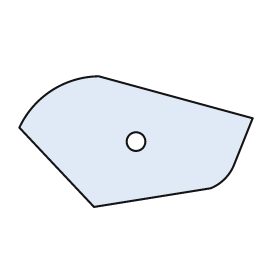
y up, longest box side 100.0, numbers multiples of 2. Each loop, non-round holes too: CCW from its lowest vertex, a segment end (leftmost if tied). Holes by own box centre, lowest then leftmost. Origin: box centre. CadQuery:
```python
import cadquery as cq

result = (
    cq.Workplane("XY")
    .moveTo(-18.0, -28.0)
    .lineTo(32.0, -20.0)
    .threePointArc((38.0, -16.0), (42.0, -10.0))
    .lineTo(50.0, 10.0)
    .lineTo(-16.0, 28.0)
    .threePointArc((-36.0, 22.0), (-50.0, 6.0))
    .close()
    .moveTo(0.0, 0.0)
    .circle(4.0)
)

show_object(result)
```